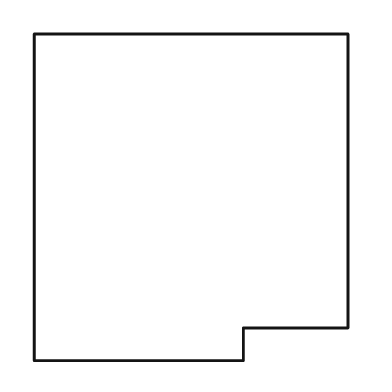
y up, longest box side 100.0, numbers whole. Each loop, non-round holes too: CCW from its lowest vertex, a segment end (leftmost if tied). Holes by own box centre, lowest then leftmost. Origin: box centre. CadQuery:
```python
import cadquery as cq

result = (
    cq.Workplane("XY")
    .moveTo(-48.0, -50.0)
    .lineTo(16.0, -50.0)
    .lineTo(16.0, -40.0)
    .lineTo(48.0, -40.0)
    .lineTo(48.0, 50.0)
    .lineTo(-48.0, 50.0)
    .close()
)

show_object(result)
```